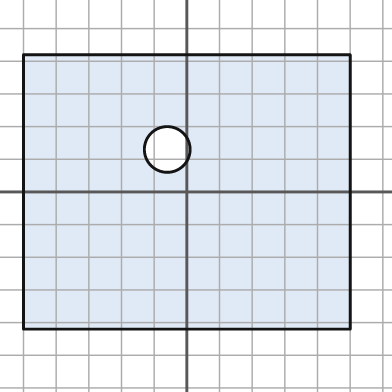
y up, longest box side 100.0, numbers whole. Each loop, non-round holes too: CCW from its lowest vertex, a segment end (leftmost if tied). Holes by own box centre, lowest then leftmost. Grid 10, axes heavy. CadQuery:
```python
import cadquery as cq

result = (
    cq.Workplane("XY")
    .moveTo(-50.0, -42.0)
    .lineTo(50.0, -42.0)
    .lineTo(50.0, 42.0)
    .lineTo(-50.0, 42.0)
    .close()
    .moveTo(-6.0, 13.0)
    .circle(7.0)
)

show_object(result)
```